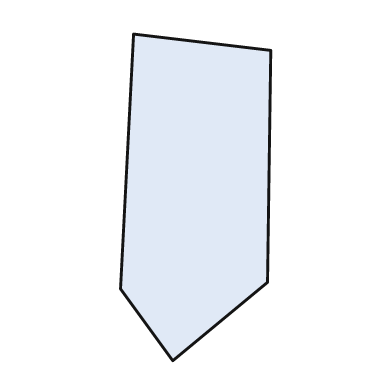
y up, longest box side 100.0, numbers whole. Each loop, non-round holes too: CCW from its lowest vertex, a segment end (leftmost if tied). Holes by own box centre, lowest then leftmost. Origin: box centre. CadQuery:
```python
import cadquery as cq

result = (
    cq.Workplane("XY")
    .moveTo(-7.0, -50.0)
    .lineTo(22.0, -26.0)
    .lineTo(23.0, 45.0)
    .lineTo(-19.0, 50.0)
    .lineTo(-23.0, -28.0)
    .close()
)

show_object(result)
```